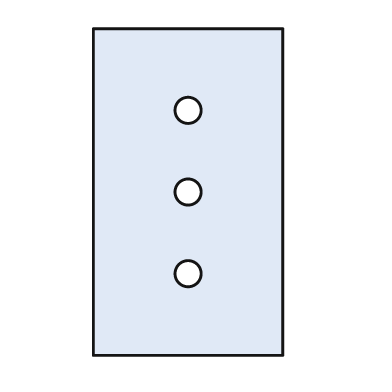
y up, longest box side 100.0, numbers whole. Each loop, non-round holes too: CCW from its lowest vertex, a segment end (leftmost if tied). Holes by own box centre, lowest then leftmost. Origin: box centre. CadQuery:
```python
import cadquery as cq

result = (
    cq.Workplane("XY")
    .moveTo(-29.0, -50.0)
    .lineTo(29.0, -50.0)
    .lineTo(29.0, 50.0)
    .lineTo(-29.0, 50.0)
    .close()
    .moveTo(0.0, -25.0)
    .circle(4.0)
    .moveTo(0.0, 0.0)
    .circle(4.0)
    .moveTo(0.0, 25.0)
    .circle(4.0)
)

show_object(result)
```